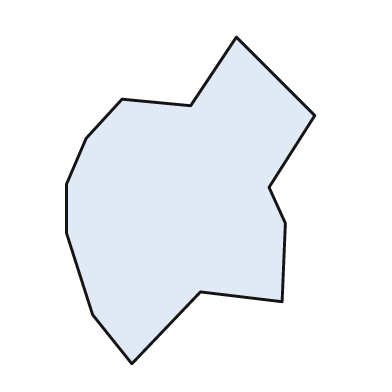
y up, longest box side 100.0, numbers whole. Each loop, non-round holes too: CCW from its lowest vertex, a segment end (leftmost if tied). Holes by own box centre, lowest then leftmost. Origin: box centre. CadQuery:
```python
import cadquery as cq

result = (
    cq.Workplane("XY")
    .moveTo(-18.0, -50.0)
    .lineTo(3.0, -28.0)
    .lineTo(28.0, -31.0)
    .lineTo(29.0, -7.0)
    .lineTo(24.0, 4.0)
    .lineTo(38.0, 26.0)
    .lineTo(14.0, 50.0)
    .lineTo(0.0, 29.0)
    .lineTo(-21.0, 31.0)
    .lineTo(-32.0, 19.0)
    .lineTo(-38.0, 5.0)
    .lineTo(-38.0, -10.0)
    .lineTo(-30.0, -35.0)
    .close()
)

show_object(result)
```